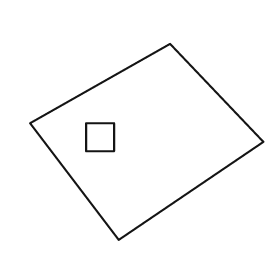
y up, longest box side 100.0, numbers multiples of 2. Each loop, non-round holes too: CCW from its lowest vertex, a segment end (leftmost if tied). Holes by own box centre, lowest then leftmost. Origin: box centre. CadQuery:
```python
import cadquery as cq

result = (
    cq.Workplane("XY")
    .moveTo(-12.0, -42.0)
    .lineTo(50.0, 0.0)
    .lineTo(10.0, 42.0)
    .lineTo(-50.0, 8.0)
    .close()
    .moveTo(-26.0, -4.0)
    .lineTo(-14.0, -4.0)
    .lineTo(-14.0, 8.0)
    .lineTo(-26.0, 8.0)
    .close()
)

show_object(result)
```